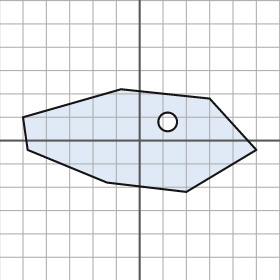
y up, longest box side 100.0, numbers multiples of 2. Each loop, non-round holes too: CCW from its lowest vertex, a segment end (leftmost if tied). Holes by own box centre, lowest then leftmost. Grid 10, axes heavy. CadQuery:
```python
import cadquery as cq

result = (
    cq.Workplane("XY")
    .moveTo(20.0, -22.0)
    .lineTo(50.0, -4.0)
    .lineTo(30.0, 18.0)
    .lineTo(-8.0, 22.0)
    .lineTo(-50.0, 10.0)
    .lineTo(-48.0, -4.0)
    .lineTo(-14.0, -18.0)
    .close()
    .moveTo(12.0, 8.0)
    .circle(4.0)
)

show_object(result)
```